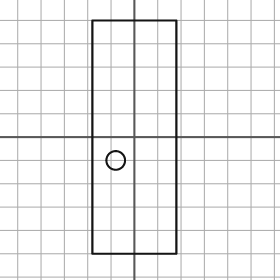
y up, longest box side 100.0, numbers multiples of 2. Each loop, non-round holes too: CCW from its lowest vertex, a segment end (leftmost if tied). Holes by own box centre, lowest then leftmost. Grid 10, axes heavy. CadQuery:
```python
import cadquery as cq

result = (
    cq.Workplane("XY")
    .moveTo(-18.0, -50.0)
    .lineTo(18.0, -50.0)
    .lineTo(18.0, 50.0)
    .lineTo(-18.0, 50.0)
    .close()
    .moveTo(-8.0, -10.0)
    .circle(4.0)
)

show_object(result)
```